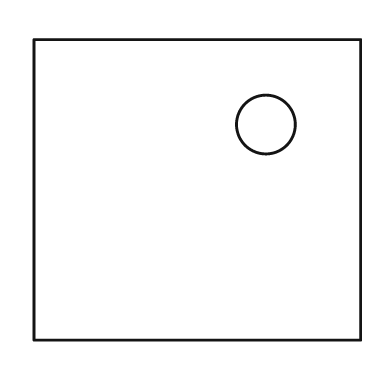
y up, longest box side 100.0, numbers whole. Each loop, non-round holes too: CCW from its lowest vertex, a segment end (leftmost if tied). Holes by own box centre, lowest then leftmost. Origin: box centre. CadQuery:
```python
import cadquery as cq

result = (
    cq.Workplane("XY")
    .moveTo(-50.0, -46.0)
    .lineTo(50.0, -46.0)
    .lineTo(50.0, 46.0)
    .lineTo(-50.0, 46.0)
    .close()
    .moveTo(21.0, 20.0)
    .circle(9.0)
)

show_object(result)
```